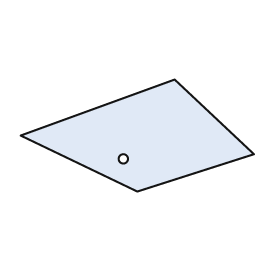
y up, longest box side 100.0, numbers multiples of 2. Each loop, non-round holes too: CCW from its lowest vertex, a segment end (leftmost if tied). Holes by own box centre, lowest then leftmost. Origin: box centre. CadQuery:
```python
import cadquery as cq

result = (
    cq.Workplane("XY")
    .moveTo(0.0, -24.0)
    .lineTo(50.0, -8.0)
    .lineTo(16.0, 24.0)
    .lineTo(-50.0, 0.0)
    .close()
    .moveTo(-6.0, -10.0)
    .circle(2.0)
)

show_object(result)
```